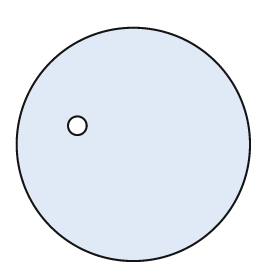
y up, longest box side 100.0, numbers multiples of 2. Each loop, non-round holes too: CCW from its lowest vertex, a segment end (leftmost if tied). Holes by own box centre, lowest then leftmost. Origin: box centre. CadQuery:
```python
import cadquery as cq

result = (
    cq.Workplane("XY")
    .moveTo(0.0, 0.0)
    .circle(50.0)
    .moveTo(-24.0, 8.0)
    .circle(4.0)
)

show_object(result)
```